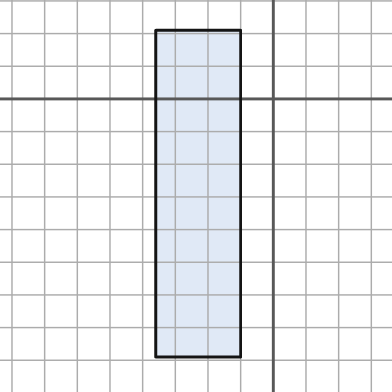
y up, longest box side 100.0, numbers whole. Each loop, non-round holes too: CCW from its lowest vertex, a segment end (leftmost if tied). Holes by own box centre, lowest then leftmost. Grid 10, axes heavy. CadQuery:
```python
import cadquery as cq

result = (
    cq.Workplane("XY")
    .moveTo(-36.0, -79.0)
    .lineTo(-10.0, -79.0)
    .lineTo(-10.0, 21.0)
    .lineTo(-36.0, 21.0)
    .close()
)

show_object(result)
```